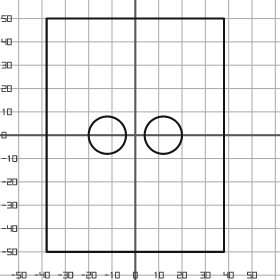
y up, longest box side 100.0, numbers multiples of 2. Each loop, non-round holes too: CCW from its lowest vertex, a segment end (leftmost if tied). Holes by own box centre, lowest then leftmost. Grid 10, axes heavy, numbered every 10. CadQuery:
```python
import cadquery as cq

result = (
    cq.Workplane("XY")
    .moveTo(-38.0, -50.0)
    .lineTo(38.0, -50.0)
    .lineTo(38.0, 50.0)
    .lineTo(-38.0, 50.0)
    .close()
    .moveTo(-12.0, 0.0)
    .circle(8.0)
    .moveTo(12.0, 0.0)
    .circle(8.0)
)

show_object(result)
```